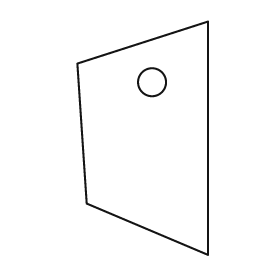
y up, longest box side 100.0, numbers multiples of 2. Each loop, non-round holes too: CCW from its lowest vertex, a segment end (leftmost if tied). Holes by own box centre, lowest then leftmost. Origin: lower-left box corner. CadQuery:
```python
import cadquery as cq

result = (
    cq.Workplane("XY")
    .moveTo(56.0, 0.0)
    .lineTo(56.0, 100.0)
    .lineTo(0.0, 82.0)
    .lineTo(4.0, 22.0)
    .close()
    .moveTo(32.0, 74.0)
    .circle(6.0)
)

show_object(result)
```